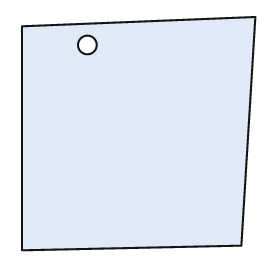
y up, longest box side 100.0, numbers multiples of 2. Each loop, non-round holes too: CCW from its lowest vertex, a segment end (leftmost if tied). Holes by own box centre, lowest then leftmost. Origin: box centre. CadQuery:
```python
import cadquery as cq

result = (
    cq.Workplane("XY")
    .moveTo(-50.0, -50.0)
    .lineTo(44.0, -48.0)
    .lineTo(50.0, 50.0)
    .lineTo(-50.0, 46.0)
    .close()
    .moveTo(-22.0, 38.0)
    .circle(4.0)
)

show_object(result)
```